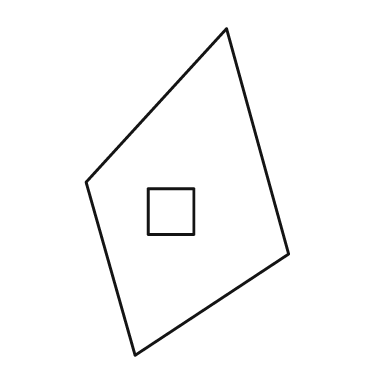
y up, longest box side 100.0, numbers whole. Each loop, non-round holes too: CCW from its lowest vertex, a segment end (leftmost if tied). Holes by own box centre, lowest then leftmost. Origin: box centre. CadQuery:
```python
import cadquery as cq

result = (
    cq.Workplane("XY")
    .moveTo(-16.0, -50.0)
    .lineTo(31.0, -19.0)
    .lineTo(12.0, 50.0)
    .lineTo(-31.0, 3.0)
    .close()
    .moveTo(-12.0, -13.0)
    .lineTo(2.0, -13.0)
    .lineTo(2.0, 1.0)
    .lineTo(-12.0, 1.0)
    .close()
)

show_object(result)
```